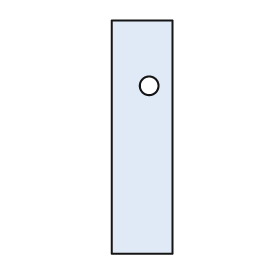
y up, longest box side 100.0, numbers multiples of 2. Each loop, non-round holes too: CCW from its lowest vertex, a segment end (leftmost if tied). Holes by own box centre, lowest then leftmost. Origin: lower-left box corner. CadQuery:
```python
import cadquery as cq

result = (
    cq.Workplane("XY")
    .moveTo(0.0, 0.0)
    .lineTo(26.0, 0.0)
    .lineTo(26.0, 100.0)
    .lineTo(0.0, 100.0)
    .close()
    .moveTo(16.0, 72.0)
    .circle(4.0)
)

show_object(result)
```